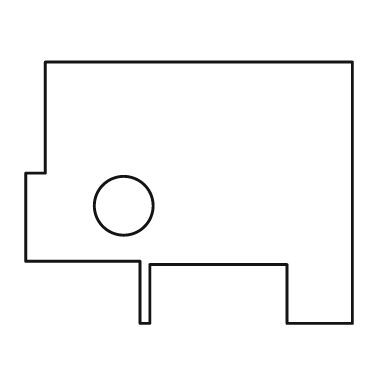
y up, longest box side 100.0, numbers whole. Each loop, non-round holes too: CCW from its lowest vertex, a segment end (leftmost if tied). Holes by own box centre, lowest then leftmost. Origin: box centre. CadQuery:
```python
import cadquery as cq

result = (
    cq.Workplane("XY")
    .moveTo(-15.0, -40.0)
    .lineTo(-12.0, -40.0)
    .lineTo(-12.0, -22.0)
    .lineTo(30.0, -22.0)
    .lineTo(30.0, -40.0)
    .lineTo(50.0, -40.0)
    .lineTo(50.0, 40.0)
    .lineTo(-44.0, 40.0)
    .lineTo(-44.0, 6.0)
    .lineTo(-50.0, 6.0)
    .lineTo(-50.0, -21.0)
    .lineTo(-15.0, -21.0)
    .close()
    .moveTo(-20.0, -4.0)
    .circle(9.0)
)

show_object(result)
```